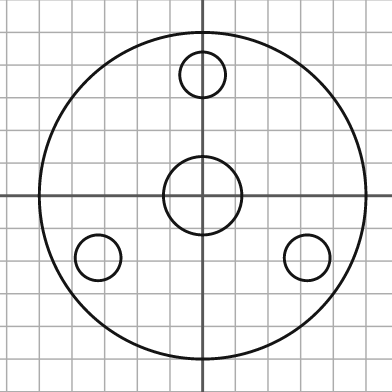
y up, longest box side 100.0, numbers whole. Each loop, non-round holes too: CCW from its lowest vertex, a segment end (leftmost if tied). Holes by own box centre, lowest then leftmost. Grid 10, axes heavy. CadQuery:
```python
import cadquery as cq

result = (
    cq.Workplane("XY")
    .moveTo(0.0, 0.0)
    .circle(50.0)
    .moveTo(-32.0, -19.0)
    .circle(7.0)
    .moveTo(32.0, -19.0)
    .circle(7.0)
    .moveTo(0.0, 0.0)
    .circle(12.0)
    .moveTo(0.0, 37.0)
    .circle(7.0)
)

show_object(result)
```